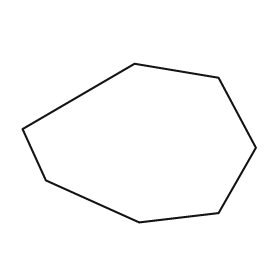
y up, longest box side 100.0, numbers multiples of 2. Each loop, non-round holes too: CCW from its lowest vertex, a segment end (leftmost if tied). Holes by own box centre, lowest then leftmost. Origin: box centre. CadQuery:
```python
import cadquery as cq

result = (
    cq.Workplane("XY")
    .moveTo(0.0, -34.0)
    .lineTo(34.0, -30.0)
    .lineTo(50.0, -2.0)
    .lineTo(34.0, 28.0)
    .lineTo(-2.0, 34.0)
    .lineTo(-50.0, 6.0)
    .lineTo(-40.0, -16.0)
    .close()
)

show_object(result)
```